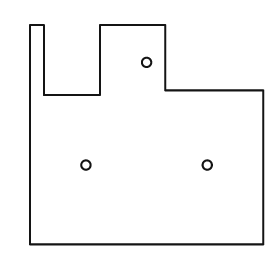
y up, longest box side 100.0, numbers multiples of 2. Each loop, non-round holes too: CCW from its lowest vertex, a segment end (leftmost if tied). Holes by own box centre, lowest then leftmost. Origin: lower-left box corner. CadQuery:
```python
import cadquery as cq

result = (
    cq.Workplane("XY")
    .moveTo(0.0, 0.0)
    .lineTo(100.0, 0.0)
    .lineTo(100.0, 66.0)
    .lineTo(58.0, 66.0)
    .lineTo(58.0, 94.0)
    .lineTo(30.0, 94.0)
    .lineTo(30.0, 64.0)
    .lineTo(6.0, 64.0)
    .lineTo(6.0, 94.0)
    .lineTo(0.0, 94.0)
    .close()
    .moveTo(24.0, 34.0)
    .circle(2.0)
    .moveTo(76.0, 34.0)
    .circle(2.0)
    .moveTo(50.0, 78.0)
    .circle(2.0)
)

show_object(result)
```